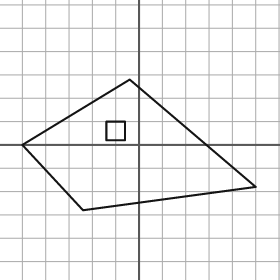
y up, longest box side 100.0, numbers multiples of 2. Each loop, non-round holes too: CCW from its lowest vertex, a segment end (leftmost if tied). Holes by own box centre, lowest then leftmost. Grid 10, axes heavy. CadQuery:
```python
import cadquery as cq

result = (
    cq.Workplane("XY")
    .moveTo(-24.0, -28.0)
    .lineTo(50.0, -18.0)
    .lineTo(-4.0, 28.0)
    .lineTo(-50.0, 0.0)
    .close()
    .moveTo(-14.0, 2.0)
    .lineTo(-6.0, 2.0)
    .lineTo(-6.0, 10.0)
    .lineTo(-14.0, 10.0)
    .close()
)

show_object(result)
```